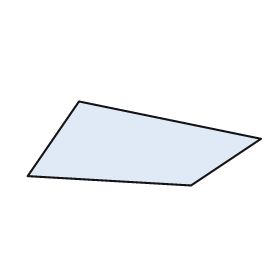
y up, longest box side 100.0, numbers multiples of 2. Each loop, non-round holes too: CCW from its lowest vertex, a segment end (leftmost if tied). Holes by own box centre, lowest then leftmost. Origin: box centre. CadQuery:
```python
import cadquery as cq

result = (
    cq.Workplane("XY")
    .moveTo(20.0, -18.0)
    .lineTo(50.0, 2.0)
    .lineTo(-28.0, 18.0)
    .lineTo(-50.0, -14.0)
    .close()
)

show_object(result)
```